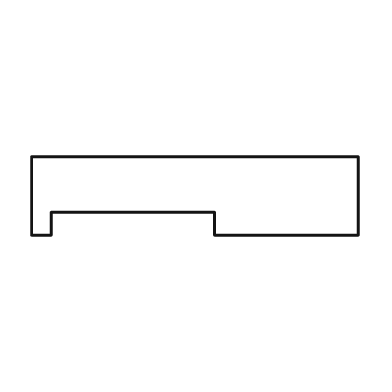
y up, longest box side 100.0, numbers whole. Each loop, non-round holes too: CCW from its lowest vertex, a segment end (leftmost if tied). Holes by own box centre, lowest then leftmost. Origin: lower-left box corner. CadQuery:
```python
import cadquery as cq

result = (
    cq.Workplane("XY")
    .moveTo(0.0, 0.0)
    .lineTo(6.0, 0.0)
    .lineTo(6.0, 7.0)
    .lineTo(56.0, 7.0)
    .lineTo(56.0, 0.0)
    .lineTo(100.0, 0.0)
    .lineTo(100.0, 24.0)
    .lineTo(0.0, 24.0)
    .close()
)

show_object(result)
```